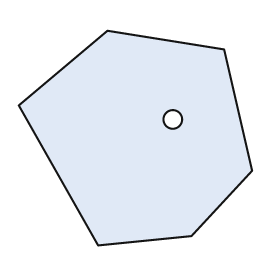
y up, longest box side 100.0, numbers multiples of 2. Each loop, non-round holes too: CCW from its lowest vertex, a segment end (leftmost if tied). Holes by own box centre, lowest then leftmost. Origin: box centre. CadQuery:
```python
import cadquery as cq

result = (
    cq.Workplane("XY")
    .moveTo(-16.0, -46.0)
    .lineTo(24.0, -42.0)
    .lineTo(50.0, -14.0)
    .lineTo(38.0, 38.0)
    .lineTo(-12.0, 46.0)
    .lineTo(-50.0, 14.0)
    .close()
    .moveTo(16.0, 8.0)
    .circle(4.0)
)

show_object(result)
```